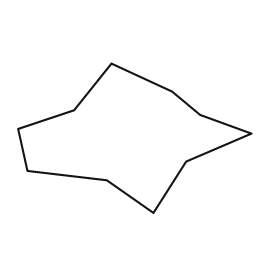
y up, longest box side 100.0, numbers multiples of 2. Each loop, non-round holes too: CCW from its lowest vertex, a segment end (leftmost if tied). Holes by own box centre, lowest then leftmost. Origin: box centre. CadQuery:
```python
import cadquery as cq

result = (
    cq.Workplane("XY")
    .moveTo(8.0, -32.0)
    .lineTo(22.0, -10.0)
    .lineTo(50.0, 2.0)
    .lineTo(28.0, 10.0)
    .lineTo(16.0, 20.0)
    .lineTo(-10.0, 32.0)
    .lineTo(-26.0, 12.0)
    .lineTo(-50.0, 4.0)
    .lineTo(-46.0, -14.0)
    .lineTo(-12.0, -18.0)
    .close()
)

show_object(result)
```